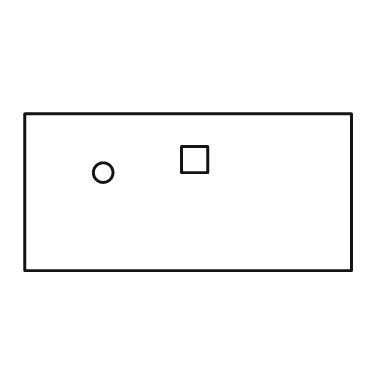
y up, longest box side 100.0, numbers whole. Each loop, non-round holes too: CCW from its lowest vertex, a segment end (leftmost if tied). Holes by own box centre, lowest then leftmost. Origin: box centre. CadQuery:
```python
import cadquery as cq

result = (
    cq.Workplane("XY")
    .moveTo(-50.0, -24.0)
    .lineTo(50.0, -24.0)
    .lineTo(50.0, 24.0)
    .lineTo(-50.0, 24.0)
    .close()
    .moveTo(-26.0, 6.0)
    .circle(3.0)
    .moveTo(-2.0, 6.0)
    .lineTo(6.0, 6.0)
    .lineTo(6.0, 14.0)
    .lineTo(-2.0, 14.0)
    .close()
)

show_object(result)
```